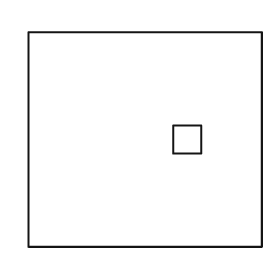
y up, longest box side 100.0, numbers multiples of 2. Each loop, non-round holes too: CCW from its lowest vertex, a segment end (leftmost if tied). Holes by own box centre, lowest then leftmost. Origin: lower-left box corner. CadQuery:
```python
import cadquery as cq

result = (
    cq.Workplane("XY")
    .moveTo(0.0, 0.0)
    .lineTo(100.0, 0.0)
    .lineTo(100.0, 92.0)
    .lineTo(0.0, 92.0)
    .close()
    .moveTo(62.0, 40.0)
    .lineTo(74.0, 40.0)
    .lineTo(74.0, 52.0)
    .lineTo(62.0, 52.0)
    .close()
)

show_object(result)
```